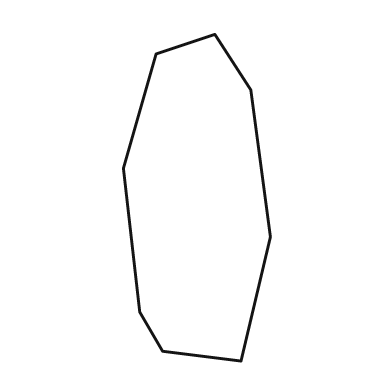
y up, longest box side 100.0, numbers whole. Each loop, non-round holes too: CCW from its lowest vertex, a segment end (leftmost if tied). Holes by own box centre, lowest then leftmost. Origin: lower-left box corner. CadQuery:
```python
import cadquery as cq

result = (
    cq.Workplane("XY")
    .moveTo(36.0, 0.0)
    .lineTo(45.0, 38.0)
    .lineTo(39.0, 83.0)
    .lineTo(28.0, 100.0)
    .lineTo(10.0, 94.0)
    .lineTo(0.0, 59.0)
    .lineTo(5.0, 15.0)
    .lineTo(12.0, 3.0)
    .close()
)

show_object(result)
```